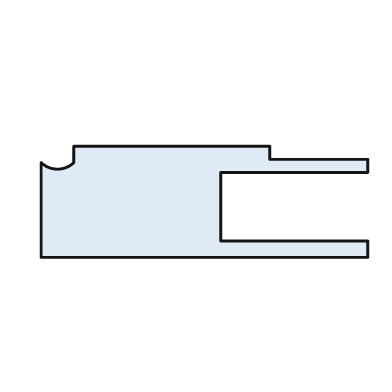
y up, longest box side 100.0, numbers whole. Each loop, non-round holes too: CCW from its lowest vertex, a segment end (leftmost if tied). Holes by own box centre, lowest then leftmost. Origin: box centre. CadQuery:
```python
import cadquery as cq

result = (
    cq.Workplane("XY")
    .moveTo(-50.0, -17.0)
    .lineTo(50.0, -17.0)
    .lineTo(50.0, -12.0)
    .lineTo(5.0, -12.0)
    .lineTo(5.0, 9.0)
    .lineTo(50.0, 9.0)
    .lineTo(50.0, 13.0)
    .lineTo(20.0, 13.0)
    .lineTo(20.0, 17.0)
    .lineTo(-40.0, 17.0)
    .lineTo(-40.0, 12.0)
    .threePointArc((-45.0, 10.0), (-50.0, 12.0))
    .close()
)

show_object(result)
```